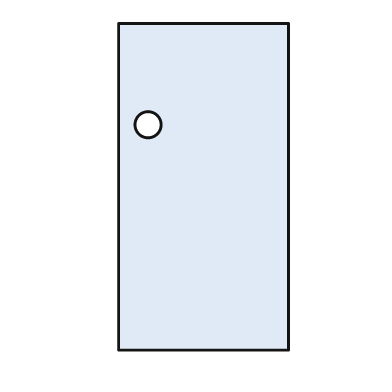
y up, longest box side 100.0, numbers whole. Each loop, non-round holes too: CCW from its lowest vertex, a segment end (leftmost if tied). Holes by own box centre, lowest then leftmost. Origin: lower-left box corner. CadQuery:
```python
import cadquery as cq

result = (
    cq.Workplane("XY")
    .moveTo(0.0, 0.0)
    .lineTo(52.0, 0.0)
    .lineTo(52.0, 100.0)
    .lineTo(0.0, 100.0)
    .close()
    .moveTo(9.0, 69.0)
    .circle(4.0)
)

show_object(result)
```